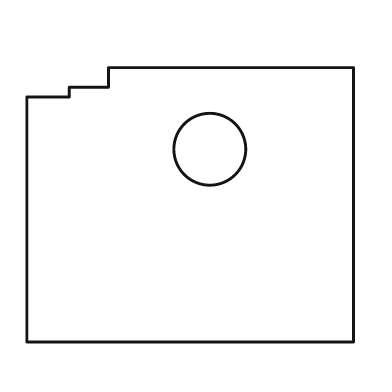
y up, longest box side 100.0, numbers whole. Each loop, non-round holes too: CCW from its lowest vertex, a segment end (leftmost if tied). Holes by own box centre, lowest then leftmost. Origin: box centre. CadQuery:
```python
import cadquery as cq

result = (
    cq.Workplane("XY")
    .moveTo(-50.0, -42.0)
    .lineTo(50.0, -42.0)
    .lineTo(50.0, 42.0)
    .lineTo(-25.0, 42.0)
    .lineTo(-25.0, 36.0)
    .lineTo(-37.0, 36.0)
    .lineTo(-37.0, 33.0)
    .lineTo(-50.0, 33.0)
    .close()
    .moveTo(6.0, 17.0)
    .circle(11.0)
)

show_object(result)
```